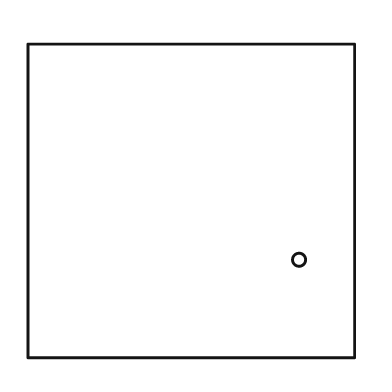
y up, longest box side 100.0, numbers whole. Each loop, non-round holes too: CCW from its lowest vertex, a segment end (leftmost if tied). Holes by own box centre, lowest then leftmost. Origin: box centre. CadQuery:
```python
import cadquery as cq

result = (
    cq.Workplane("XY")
    .moveTo(-50.0, -48.0)
    .lineTo(50.0, -48.0)
    .lineTo(50.0, 48.0)
    .lineTo(-50.0, 48.0)
    .close()
    .moveTo(33.0, -18.0)
    .circle(2.0)
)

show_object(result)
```